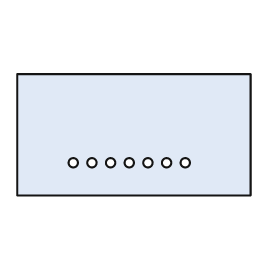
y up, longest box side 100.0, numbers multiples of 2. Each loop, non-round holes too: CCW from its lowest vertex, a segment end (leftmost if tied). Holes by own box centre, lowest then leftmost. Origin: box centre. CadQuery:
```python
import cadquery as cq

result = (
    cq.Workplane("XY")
    .moveTo(-50.0, -26.0)
    .lineTo(50.0, -26.0)
    .lineTo(50.0, 26.0)
    .lineTo(-50.0, 26.0)
    .close()
    .moveTo(-26.0, -12.0)
    .circle(2.0)
    .moveTo(-18.0, -12.0)
    .circle(2.0)
    .moveTo(-10.0, -12.0)
    .circle(2.0)
    .moveTo(-2.0, -12.0)
    .circle(2.0)
    .moveTo(6.0, -12.0)
    .circle(2.0)
    .moveTo(14.0, -12.0)
    .circle(2.0)
    .moveTo(22.0, -12.0)
    .circle(2.0)
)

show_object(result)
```